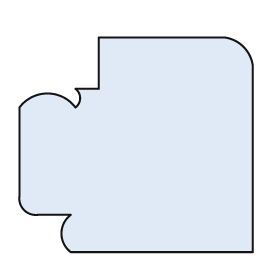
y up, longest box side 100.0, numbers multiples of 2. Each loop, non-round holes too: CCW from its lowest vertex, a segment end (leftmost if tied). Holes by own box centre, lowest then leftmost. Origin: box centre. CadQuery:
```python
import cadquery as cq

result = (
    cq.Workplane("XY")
    .moveTo(-28.0, -46.0)
    .lineTo(50.0, -46.0)
    .lineTo(50.0, 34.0)
    .threePointArc((46.0, 42.0), (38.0, 46.0))
    .lineTo(-16.0, 46.0)
    .lineTo(-16.0, 24.0)
    .lineTo(-26.0, 24.0)
    .threePointArc((-24.0, 20.0), (-26.0, 16.0))
    .threePointArc((-38.0, 22.0), (-50.0, 16.0))
    .lineTo(-50.0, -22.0)
    .threePointArc((-48.0, -28.0), (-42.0, -30.0))
    .lineTo(-28.0, -30.0)
    .threePointArc((-32.0, -38.0), (-28.0, -46.0))
    .close()
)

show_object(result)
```